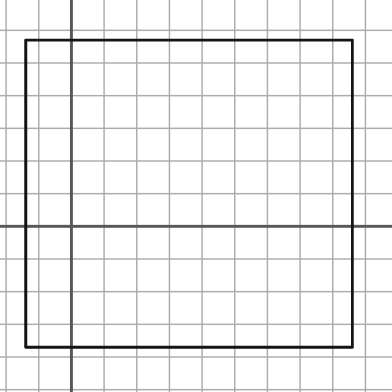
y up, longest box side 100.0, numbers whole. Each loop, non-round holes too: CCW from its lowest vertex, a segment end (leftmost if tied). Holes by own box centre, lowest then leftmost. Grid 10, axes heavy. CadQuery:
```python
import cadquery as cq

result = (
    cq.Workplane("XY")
    .moveTo(-14.0, -37.0)
    .lineTo(86.0, -37.0)
    .lineTo(86.0, 57.0)
    .lineTo(-14.0, 57.0)
    .close()
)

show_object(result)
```